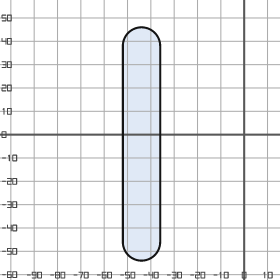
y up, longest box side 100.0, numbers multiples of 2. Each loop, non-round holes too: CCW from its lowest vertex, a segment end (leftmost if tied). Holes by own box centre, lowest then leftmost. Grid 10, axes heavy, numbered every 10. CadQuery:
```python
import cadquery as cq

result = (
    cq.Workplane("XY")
    .moveTo(-52.0, -46.0)
    .threePointArc((-44.0, -54.0), (-36.0, -46.0))
    .lineTo(-36.0, 38.0)
    .threePointArc((-44.0, 46.0), (-52.0, 38.0))
    .close()
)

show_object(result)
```